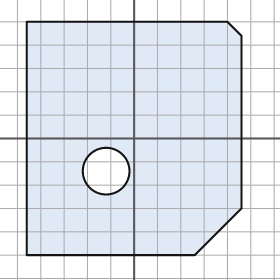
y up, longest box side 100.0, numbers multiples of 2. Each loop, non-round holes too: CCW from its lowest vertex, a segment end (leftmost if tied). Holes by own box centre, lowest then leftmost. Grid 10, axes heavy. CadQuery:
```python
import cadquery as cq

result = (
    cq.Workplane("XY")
    .moveTo(-46.0, -50.0)
    .lineTo(26.0, -50.0)
    .lineTo(46.0, -30.0)
    .lineTo(46.0, 44.0)
    .lineTo(40.0, 50.0)
    .lineTo(-46.0, 50.0)
    .close()
    .moveTo(-12.0, -14.0)
    .circle(10.0)
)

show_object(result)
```